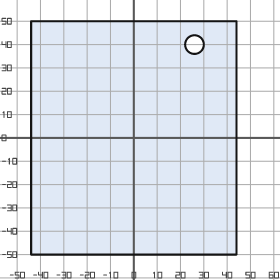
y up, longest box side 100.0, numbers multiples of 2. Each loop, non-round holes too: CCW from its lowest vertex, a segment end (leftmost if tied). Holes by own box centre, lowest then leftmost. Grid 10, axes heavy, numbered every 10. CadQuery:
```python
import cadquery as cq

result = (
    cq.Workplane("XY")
    .moveTo(-44.0, -50.0)
    .lineTo(44.0, -50.0)
    .lineTo(44.0, 50.0)
    .lineTo(-44.0, 50.0)
    .close()
    .moveTo(26.0, 40.0)
    .circle(4.0)
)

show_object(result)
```